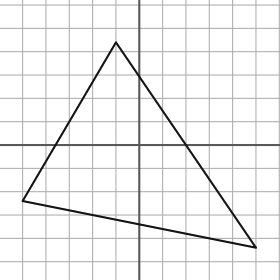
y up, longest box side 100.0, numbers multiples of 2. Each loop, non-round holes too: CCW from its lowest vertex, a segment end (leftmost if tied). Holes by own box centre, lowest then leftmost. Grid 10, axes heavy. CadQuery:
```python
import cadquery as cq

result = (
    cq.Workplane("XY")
    .moveTo(50.0, -44.0)
    .lineTo(-10.0, 44.0)
    .lineTo(-50.0, -24.0)
    .close()
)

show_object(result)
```